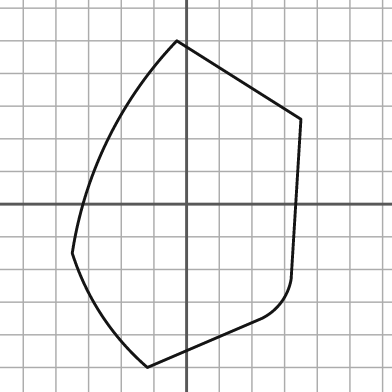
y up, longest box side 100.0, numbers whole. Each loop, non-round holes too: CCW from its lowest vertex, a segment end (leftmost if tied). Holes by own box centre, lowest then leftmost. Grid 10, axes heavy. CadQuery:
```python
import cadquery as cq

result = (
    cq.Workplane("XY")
    .moveTo(-12.0, -50.0)
    .lineTo(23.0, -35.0)
    .threePointArc((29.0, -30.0), (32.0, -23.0))
    .lineTo(35.0, 26.0)
    .lineTo(-3.0, 50.0)
    .threePointArc((-24.0, 20.0), (-35.0, -15.0))
    .threePointArc((-26.0, -34.0), (-12.0, -50.0))
    .close()
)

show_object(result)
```